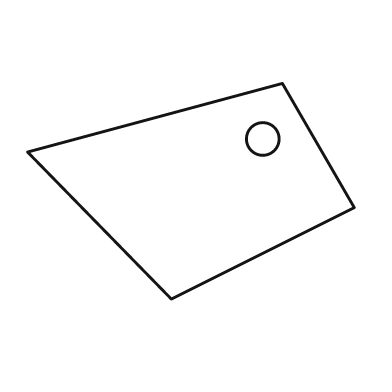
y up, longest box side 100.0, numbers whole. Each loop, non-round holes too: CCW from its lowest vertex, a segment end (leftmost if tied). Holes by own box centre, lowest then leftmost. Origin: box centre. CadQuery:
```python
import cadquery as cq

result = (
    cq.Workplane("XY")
    .moveTo(-6.0, -33.0)
    .lineTo(50.0, -5.0)
    .lineTo(28.0, 33.0)
    .lineTo(-50.0, 12.0)
    .close()
    .moveTo(22.0, 16.0)
    .circle(5.0)
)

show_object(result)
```